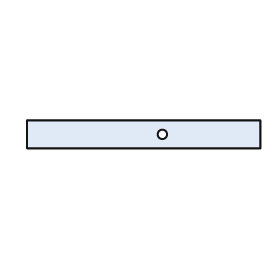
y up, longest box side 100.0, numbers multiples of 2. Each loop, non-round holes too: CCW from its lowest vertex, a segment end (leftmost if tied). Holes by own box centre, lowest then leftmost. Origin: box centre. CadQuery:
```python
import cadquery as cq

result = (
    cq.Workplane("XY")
    .moveTo(-50.0, -6.0)
    .lineTo(50.0, -6.0)
    .lineTo(50.0, 6.0)
    .lineTo(-50.0, 6.0)
    .close()
    .moveTo(8.0, 0.0)
    .circle(2.0)
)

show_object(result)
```